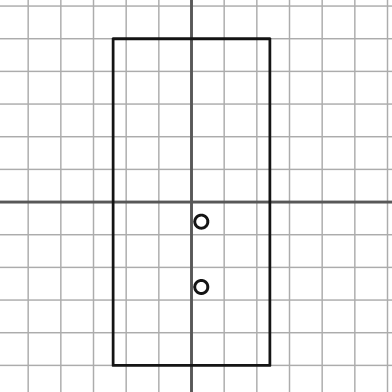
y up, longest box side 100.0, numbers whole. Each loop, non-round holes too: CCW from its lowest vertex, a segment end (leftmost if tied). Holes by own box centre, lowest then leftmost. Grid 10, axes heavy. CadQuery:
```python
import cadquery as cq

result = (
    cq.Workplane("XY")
    .moveTo(-24.0, -50.0)
    .lineTo(24.0, -50.0)
    .lineTo(24.0, 50.0)
    .lineTo(-24.0, 50.0)
    .close()
    .moveTo(3.0, -26.0)
    .circle(2.0)
    .moveTo(3.0, -6.0)
    .circle(2.0)
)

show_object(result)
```